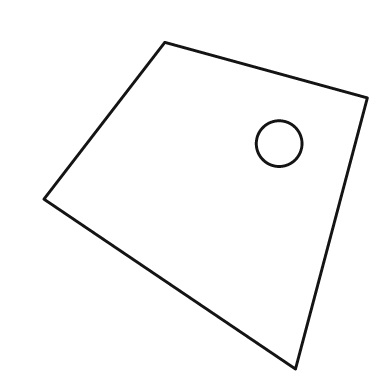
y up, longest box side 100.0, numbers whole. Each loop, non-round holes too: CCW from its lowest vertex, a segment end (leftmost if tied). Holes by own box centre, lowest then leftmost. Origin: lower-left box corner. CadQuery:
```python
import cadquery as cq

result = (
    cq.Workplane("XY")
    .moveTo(77.0, 0.0)
    .lineTo(99.0, 83.0)
    .lineTo(37.0, 100.0)
    .lineTo(0.0, 52.0)
    .close()
    .moveTo(72.0, 69.0)
    .circle(7.0)
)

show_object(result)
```